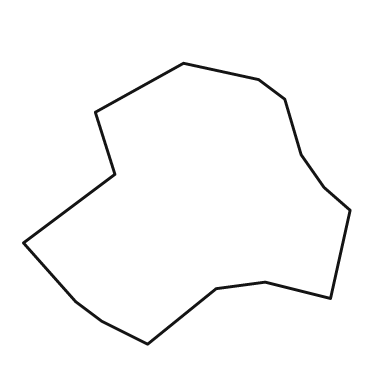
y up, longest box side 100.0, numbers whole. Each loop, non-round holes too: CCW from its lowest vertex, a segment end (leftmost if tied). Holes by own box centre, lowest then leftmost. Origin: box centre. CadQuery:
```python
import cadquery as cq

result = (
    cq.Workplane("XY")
    .moveTo(-12.0, -43.0)
    .lineTo(9.0, -26.0)
    .lineTo(24.0, -24.0)
    .lineTo(44.0, -29.0)
    .lineTo(50.0, -2.0)
    .lineTo(42.0, 5.0)
    .lineTo(35.0, 15.0)
    .lineTo(30.0, 32.0)
    .lineTo(22.0, 38.0)
    .lineTo(-1.0, 43.0)
    .lineTo(-28.0, 28.0)
    .lineTo(-22.0, 9.0)
    .lineTo(-50.0, -12.0)
    .lineTo(-34.0, -30.0)
    .lineTo(-26.0, -36.0)
    .close()
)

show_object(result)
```